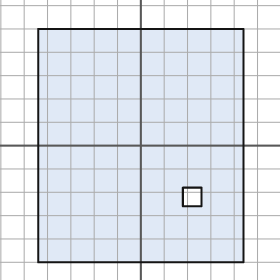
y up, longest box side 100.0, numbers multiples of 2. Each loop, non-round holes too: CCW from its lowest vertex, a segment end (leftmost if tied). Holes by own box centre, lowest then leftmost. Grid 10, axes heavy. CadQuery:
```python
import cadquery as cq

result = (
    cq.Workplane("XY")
    .moveTo(-44.0, -50.0)
    .lineTo(44.0, -50.0)
    .lineTo(44.0, 50.0)
    .lineTo(-44.0, 50.0)
    .close()
    .moveTo(18.0, -26.0)
    .lineTo(26.0, -26.0)
    .lineTo(26.0, -18.0)
    .lineTo(18.0, -18.0)
    .close()
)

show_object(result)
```